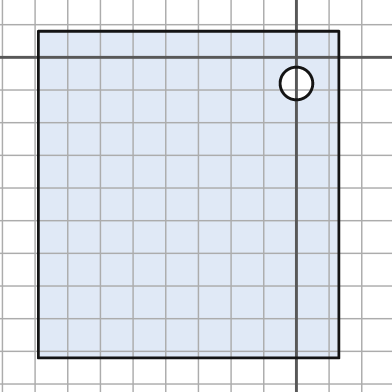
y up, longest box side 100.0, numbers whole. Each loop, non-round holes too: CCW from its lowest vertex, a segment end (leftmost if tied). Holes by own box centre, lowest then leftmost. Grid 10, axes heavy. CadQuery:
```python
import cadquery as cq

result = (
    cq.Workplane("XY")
    .moveTo(-79.0, -92.0)
    .lineTo(13.0, -92.0)
    .lineTo(13.0, 8.0)
    .lineTo(-79.0, 8.0)
    .close()
    .moveTo(0.0, -8.0)
    .circle(5.0)
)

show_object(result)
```